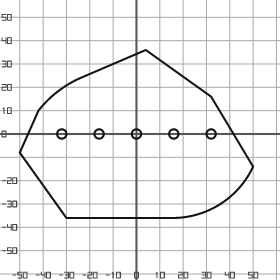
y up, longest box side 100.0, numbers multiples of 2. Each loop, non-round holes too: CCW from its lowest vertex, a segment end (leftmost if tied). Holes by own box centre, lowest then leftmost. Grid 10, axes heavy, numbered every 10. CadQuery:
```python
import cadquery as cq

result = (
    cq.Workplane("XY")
    .moveTo(-30.0, -36.0)
    .lineTo(16.0, -36.0)
    .threePointArc((36.0, -30.0), (50.0, -14.0))
    .lineTo(32.0, 16.0)
    .lineTo(4.0, 36.0)
    .lineTo(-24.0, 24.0)
    .threePointArc((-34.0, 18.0), (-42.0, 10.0))
    .lineTo(-50.0, -8.0)
    .close()
    .moveTo(-32.0, 0.0)
    .circle(2.0)
    .moveTo(-16.0, 0.0)
    .circle(2.0)
    .moveTo(0.0, 0.0)
    .circle(2.0)
    .moveTo(16.0, 0.0)
    .circle(2.0)
    .moveTo(32.0, 0.0)
    .circle(2.0)
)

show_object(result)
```